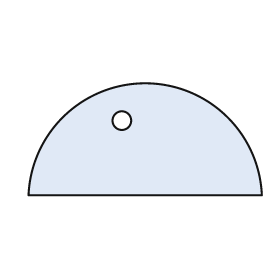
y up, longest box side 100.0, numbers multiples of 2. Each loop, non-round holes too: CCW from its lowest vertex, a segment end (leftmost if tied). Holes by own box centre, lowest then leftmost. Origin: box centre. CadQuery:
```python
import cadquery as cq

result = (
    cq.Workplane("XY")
    .moveTo(-50.0, -24.0)
    .lineTo(50.0, -24.0)
    .threePointArc((0.0, 24.0), (-50.0, -24.0))
    .close()
    .moveTo(-10.0, 8.0)
    .circle(4.0)
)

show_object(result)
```